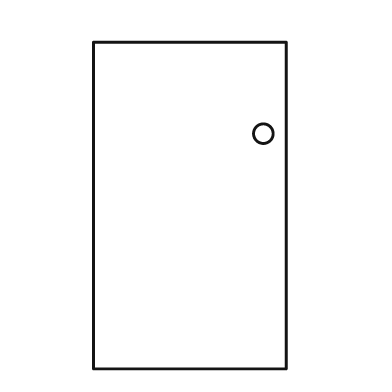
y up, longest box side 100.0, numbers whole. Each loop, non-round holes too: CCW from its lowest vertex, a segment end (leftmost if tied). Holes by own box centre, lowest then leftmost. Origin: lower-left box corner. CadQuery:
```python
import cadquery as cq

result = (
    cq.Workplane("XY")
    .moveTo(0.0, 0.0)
    .lineTo(59.0, 0.0)
    .lineTo(59.0, 100.0)
    .lineTo(0.0, 100.0)
    .close()
    .moveTo(52.0, 72.0)
    .circle(3.0)
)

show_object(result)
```